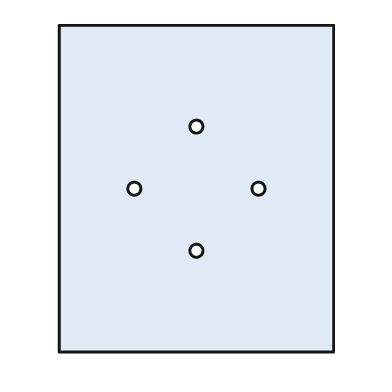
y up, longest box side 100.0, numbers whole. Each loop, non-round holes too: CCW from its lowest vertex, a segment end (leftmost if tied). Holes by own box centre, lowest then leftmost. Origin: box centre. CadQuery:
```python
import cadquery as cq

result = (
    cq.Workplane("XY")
    .moveTo(-42.0, -50.0)
    .lineTo(42.0, -50.0)
    .lineTo(42.0, 50.0)
    .lineTo(-42.0, 50.0)
    .close()
    .moveTo(0.0, -19.0)
    .circle(2.0)
    .moveTo(-19.0, 0.0)
    .circle(2.0)
    .moveTo(19.0, 0.0)
    .circle(2.0)
    .moveTo(0.0, 19.0)
    .circle(2.0)
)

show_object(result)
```